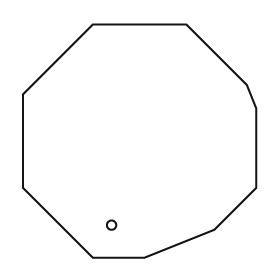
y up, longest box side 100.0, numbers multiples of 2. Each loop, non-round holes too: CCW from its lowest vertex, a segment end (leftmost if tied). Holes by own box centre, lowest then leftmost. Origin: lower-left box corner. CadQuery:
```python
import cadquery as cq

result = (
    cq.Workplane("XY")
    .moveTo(30.0, 0.0)
    .lineTo(52.0, 0.0)
    .lineTo(82.0, 12.0)
    .lineTo(100.0, 30.0)
    .lineTo(100.0, 64.0)
    .lineTo(96.0, 74.0)
    .lineTo(70.0, 100.0)
    .lineTo(30.0, 100.0)
    .lineTo(0.0, 70.0)
    .lineTo(0.0, 30.0)
    .close()
    .moveTo(38.0, 14.0)
    .circle(2.0)
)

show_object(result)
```